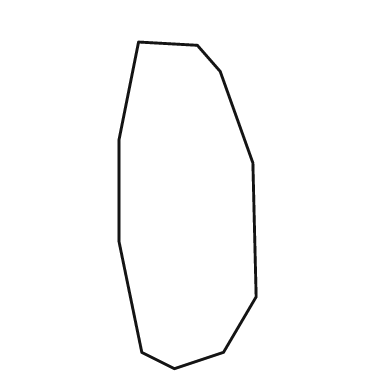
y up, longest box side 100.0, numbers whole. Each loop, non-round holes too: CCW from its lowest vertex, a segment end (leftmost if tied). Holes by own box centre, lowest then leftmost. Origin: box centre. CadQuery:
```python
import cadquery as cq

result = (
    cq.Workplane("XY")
    .moveTo(-4.0, -50.0)
    .lineTo(11.0, -45.0)
    .lineTo(21.0, -28.0)
    .lineTo(20.0, 13.0)
    .lineTo(10.0, 41.0)
    .lineTo(3.0, 49.0)
    .lineTo(-15.0, 50.0)
    .lineTo(-21.0, 20.0)
    .lineTo(-21.0, -11.0)
    .lineTo(-14.0, -45.0)
    .close()
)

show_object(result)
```